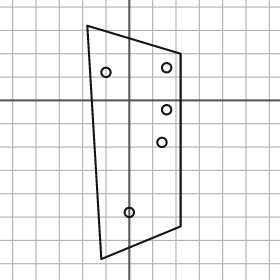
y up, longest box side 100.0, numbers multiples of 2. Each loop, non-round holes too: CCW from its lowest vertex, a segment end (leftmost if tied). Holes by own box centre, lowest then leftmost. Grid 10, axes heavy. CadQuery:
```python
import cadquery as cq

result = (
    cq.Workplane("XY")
    .moveTo(-12.0, -68.0)
    .lineTo(22.0, -54.0)
    .lineTo(22.0, 20.0)
    .lineTo(-18.0, 32.0)
    .close()
    .moveTo(0.0, -48.0)
    .circle(2.0)
    .moveTo(14.0, -18.0)
    .circle(2.0)
    .moveTo(16.0, -4.0)
    .circle(2.0)
    .moveTo(-10.0, 12.0)
    .circle(2.0)
    .moveTo(16.0, 14.0)
    .circle(2.0)
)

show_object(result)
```